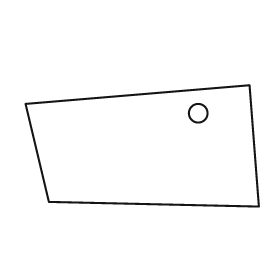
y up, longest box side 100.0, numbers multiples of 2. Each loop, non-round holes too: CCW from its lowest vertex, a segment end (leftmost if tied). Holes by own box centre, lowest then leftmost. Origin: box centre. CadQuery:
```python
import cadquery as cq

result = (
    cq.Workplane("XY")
    .moveTo(50.0, -26.0)
    .lineTo(46.0, 26.0)
    .lineTo(-50.0, 18.0)
    .lineTo(-40.0, -24.0)
    .close()
    .moveTo(24.0, 14.0)
    .circle(4.0)
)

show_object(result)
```